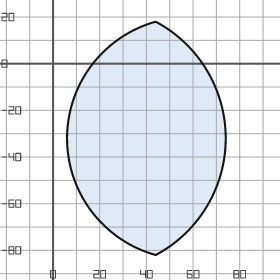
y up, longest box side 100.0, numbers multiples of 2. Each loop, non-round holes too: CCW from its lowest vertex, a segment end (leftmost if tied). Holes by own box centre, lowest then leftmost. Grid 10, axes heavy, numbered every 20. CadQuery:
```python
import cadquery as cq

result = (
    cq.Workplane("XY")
    .moveTo(44.0, -82.0)
    .threePointArc((74.0, -32.0), (44.0, 18.0))
    .threePointArc((6.0, -32.0), (44.0, -82.0))
    .close()
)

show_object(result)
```